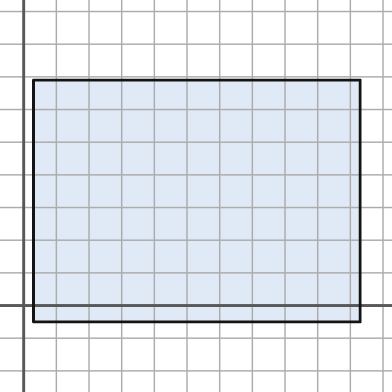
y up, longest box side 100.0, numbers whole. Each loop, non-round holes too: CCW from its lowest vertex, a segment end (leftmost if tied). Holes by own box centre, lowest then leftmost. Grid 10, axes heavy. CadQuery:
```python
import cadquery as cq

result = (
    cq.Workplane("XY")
    .moveTo(3.0, -5.0)
    .lineTo(103.0, -5.0)
    .lineTo(103.0, 69.0)
    .lineTo(3.0, 69.0)
    .close()
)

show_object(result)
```